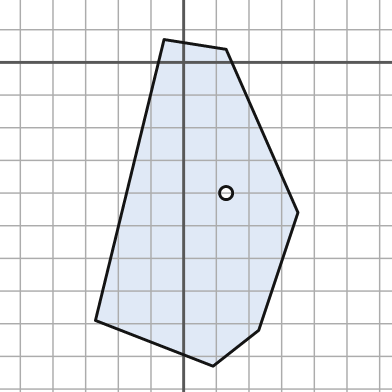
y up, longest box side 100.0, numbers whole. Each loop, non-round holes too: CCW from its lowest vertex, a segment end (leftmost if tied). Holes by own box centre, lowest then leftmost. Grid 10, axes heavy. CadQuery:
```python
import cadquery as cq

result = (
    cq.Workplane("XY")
    .moveTo(9.0, -93.0)
    .lineTo(23.0, -82.0)
    .lineTo(35.0, -46.0)
    .lineTo(13.0, 4.0)
    .lineTo(-6.0, 7.0)
    .lineTo(-27.0, -79.0)
    .close()
    .moveTo(13.0, -40.0)
    .circle(2.0)
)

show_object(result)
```